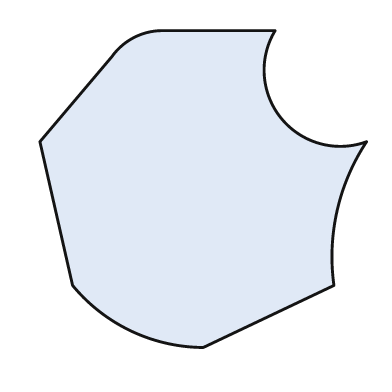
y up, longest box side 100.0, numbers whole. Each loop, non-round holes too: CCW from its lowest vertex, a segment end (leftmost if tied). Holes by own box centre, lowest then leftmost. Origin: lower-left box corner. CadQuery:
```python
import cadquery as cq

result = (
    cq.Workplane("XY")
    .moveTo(50.0, 0.0)
    .lineTo(90.0, 19.0)
    .threePointArc((91.0, 42.0), (100.0, 63.0))
    .threePointArc((74.0, 70.0), (72.0, 97.0))
    .lineTo(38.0, 97.0)
    .threePointArc((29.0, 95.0), (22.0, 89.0))
    .lineTo(0.0, 63.0)
    .lineTo(10.0, 19.0)
    .threePointArc((28.0, 5.0), (50.0, 0.0))
    .close()
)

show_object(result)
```